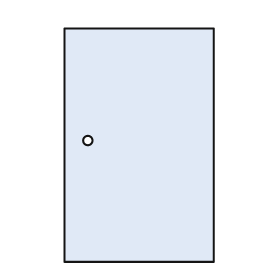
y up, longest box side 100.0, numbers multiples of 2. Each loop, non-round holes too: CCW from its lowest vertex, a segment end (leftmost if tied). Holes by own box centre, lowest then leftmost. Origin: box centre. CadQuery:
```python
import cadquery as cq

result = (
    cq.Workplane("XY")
    .moveTo(-32.0, -50.0)
    .lineTo(32.0, -50.0)
    .lineTo(32.0, 50.0)
    .lineTo(-32.0, 50.0)
    .close()
    .moveTo(-22.0, 2.0)
    .circle(2.0)
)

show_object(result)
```